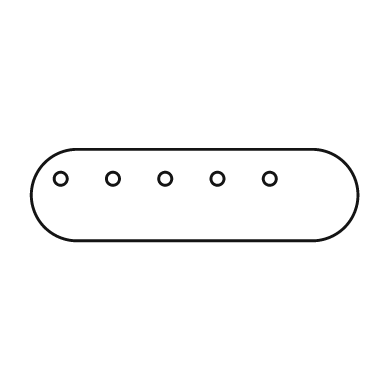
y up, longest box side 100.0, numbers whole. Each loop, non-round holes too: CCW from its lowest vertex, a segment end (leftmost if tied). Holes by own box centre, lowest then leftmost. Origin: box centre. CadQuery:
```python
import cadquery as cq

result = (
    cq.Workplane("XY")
    .moveTo(-36.0, -14.0)
    .lineTo(36.0, -14.0)
    .threePointArc((50.0, 0.0), (36.0, 14.0))
    .lineTo(-36.0, 14.0)
    .threePointArc((-50.0, 0.0), (-36.0, -14.0))
    .close()
    .moveTo(-41.0, 5.0)
    .circle(2.0)
    .moveTo(-25.0, 5.0)
    .circle(2.0)
    .moveTo(-9.0, 5.0)
    .circle(2.0)
    .moveTo(7.0, 5.0)
    .circle(2.0)
    .moveTo(23.0, 5.0)
    .circle(2.0)
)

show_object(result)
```